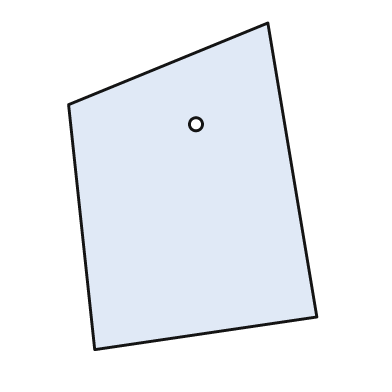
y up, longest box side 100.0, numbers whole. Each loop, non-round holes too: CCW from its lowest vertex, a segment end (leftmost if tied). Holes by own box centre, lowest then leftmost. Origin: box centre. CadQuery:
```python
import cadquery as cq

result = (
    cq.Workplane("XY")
    .moveTo(-30.0, -50.0)
    .lineTo(38.0, -40.0)
    .lineTo(23.0, 50.0)
    .lineTo(-38.0, 25.0)
    .close()
    .moveTo(1.0, 19.0)
    .circle(2.0)
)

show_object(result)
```